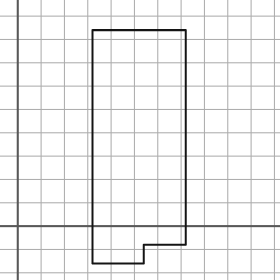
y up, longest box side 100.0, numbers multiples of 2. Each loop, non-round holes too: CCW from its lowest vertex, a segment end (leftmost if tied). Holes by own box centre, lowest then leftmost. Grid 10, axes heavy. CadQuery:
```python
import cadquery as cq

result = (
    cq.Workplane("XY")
    .moveTo(32.0, -16.0)
    .lineTo(54.0, -16.0)
    .lineTo(54.0, -8.0)
    .lineTo(72.0, -8.0)
    .lineTo(72.0, 84.0)
    .lineTo(32.0, 84.0)
    .close()
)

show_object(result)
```